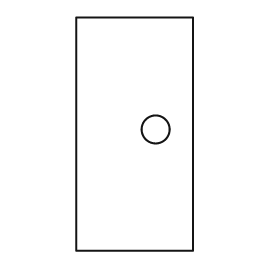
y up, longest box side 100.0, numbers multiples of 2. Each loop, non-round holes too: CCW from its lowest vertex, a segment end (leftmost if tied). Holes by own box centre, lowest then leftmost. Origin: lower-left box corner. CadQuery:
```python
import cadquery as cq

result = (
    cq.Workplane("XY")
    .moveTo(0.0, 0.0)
    .lineTo(50.0, 0.0)
    .lineTo(50.0, 100.0)
    .lineTo(0.0, 100.0)
    .close()
    .moveTo(34.0, 52.0)
    .circle(6.0)
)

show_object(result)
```